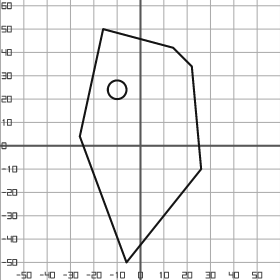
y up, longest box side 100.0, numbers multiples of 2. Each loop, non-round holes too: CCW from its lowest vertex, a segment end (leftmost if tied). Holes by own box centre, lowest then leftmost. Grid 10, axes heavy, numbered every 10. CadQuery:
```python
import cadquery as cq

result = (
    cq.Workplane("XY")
    .moveTo(-6.0, -50.0)
    .lineTo(26.0, -10.0)
    .lineTo(22.0, 34.0)
    .lineTo(14.0, 42.0)
    .lineTo(-16.0, 50.0)
    .lineTo(-26.0, 4.0)
    .close()
    .moveTo(-10.0, 24.0)
    .circle(4.0)
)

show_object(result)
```